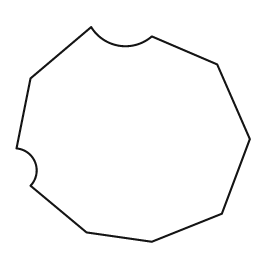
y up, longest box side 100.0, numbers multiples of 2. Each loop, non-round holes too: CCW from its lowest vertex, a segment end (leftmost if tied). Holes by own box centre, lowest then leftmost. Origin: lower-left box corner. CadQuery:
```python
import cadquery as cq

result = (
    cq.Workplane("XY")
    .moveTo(58.0, 0.0)
    .lineTo(88.0, 12.0)
    .lineTo(100.0, 44.0)
    .lineTo(86.0, 76.0)
    .lineTo(58.0, 88.0)
    .threePointArc((44.0, 84.0), (32.0, 92.0))
    .lineTo(6.0, 70.0)
    .lineTo(0.0, 40.0)
    .threePointArc((8.0, 34.0), (6.0, 24.0))
    .lineTo(30.0, 4.0)
    .close()
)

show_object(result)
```